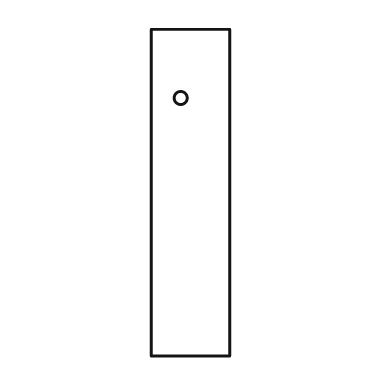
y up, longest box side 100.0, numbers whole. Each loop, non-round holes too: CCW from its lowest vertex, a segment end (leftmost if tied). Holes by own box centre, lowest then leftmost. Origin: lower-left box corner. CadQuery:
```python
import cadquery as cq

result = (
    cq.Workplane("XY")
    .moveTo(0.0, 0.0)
    .lineTo(24.0, 0.0)
    .lineTo(24.0, 100.0)
    .lineTo(0.0, 100.0)
    .close()
    .moveTo(9.0, 79.0)
    .circle(2.0)
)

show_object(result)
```